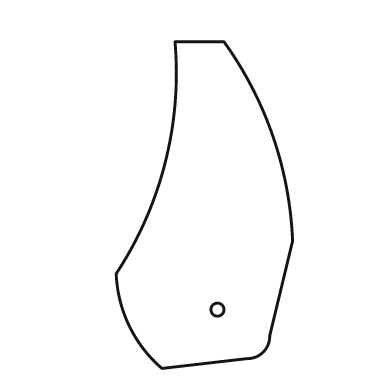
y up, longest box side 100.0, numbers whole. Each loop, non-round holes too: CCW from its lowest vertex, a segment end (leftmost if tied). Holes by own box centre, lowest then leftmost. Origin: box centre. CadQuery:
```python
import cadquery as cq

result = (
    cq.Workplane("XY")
    .moveTo(-13.0, -50.0)
    .lineTo(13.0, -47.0)
    .threePointArc((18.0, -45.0), (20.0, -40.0))
    .lineTo(27.0, -11.0)
    .threePointArc((21.0, 21.0), (6.0, 50.0))
    .lineTo(-9.0, 50.0)
    .threePointArc((-12.0, 13.0), (-27.0, -21.0))
    .threePointArc((-23.0, -37.0), (-13.0, -50.0))
    .close()
    .moveTo(4.0, -32.0)
    .circle(2.0)
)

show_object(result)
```